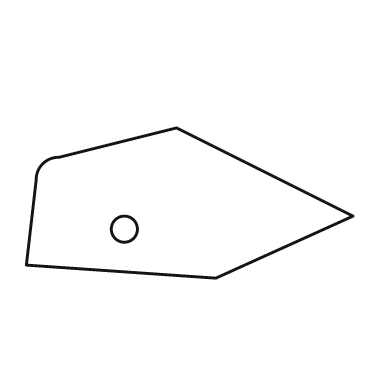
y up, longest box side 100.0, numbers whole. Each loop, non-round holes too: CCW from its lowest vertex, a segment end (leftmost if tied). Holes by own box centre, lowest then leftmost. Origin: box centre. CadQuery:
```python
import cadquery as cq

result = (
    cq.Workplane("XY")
    .moveTo(8.0, -23.0)
    .lineTo(50.0, -4.0)
    .lineTo(-4.0, 23.0)
    .lineTo(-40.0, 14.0)
    .threePointArc((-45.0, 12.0), (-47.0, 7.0))
    .lineTo(-50.0, -19.0)
    .close()
    .moveTo(-20.0, -8.0)
    .circle(4.0)
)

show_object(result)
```